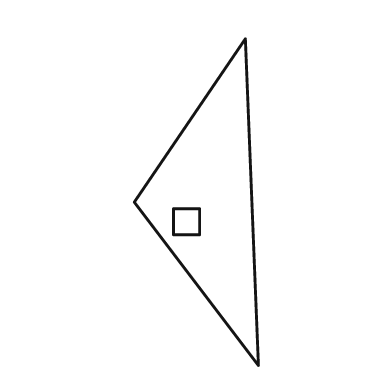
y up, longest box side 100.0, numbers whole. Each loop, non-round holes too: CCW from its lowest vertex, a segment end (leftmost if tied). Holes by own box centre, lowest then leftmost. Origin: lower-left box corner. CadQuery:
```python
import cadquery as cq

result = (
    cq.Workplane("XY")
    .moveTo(38.0, 0.0)
    .lineTo(34.0, 100.0)
    .lineTo(0.0, 50.0)
    .close()
    .moveTo(12.0, 40.0)
    .lineTo(20.0, 40.0)
    .lineTo(20.0, 48.0)
    .lineTo(12.0, 48.0)
    .close()
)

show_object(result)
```